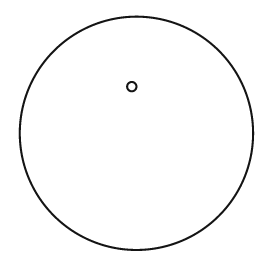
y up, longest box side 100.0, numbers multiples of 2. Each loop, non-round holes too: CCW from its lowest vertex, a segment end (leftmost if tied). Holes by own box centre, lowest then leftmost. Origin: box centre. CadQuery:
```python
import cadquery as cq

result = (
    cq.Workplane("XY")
    .moveTo(0.0, 0.0)
    .circle(50.0)
    .moveTo(-2.0, 20.0)
    .circle(2.0)
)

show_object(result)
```